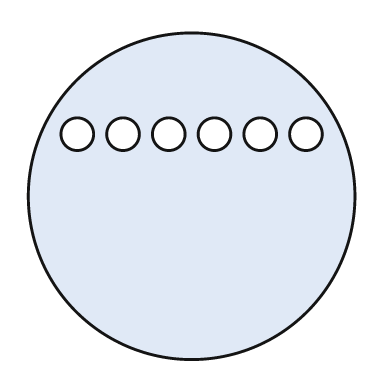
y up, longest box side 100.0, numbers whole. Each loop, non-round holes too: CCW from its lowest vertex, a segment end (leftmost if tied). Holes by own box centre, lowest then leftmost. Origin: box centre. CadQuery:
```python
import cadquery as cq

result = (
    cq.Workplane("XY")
    .moveTo(0.0, 0.0)
    .circle(50.0)
    .moveTo(-35.0, 19.0)
    .circle(5.0)
    .moveTo(-21.0, 19.0)
    .circle(5.0)
    .moveTo(-7.0, 19.0)
    .circle(5.0)
    .moveTo(7.0, 19.0)
    .circle(5.0)
    .moveTo(21.0, 19.0)
    .circle(5.0)
    .moveTo(35.0, 19.0)
    .circle(5.0)
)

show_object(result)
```